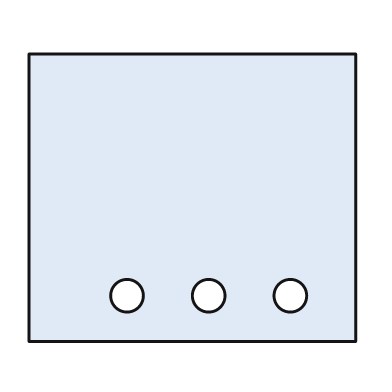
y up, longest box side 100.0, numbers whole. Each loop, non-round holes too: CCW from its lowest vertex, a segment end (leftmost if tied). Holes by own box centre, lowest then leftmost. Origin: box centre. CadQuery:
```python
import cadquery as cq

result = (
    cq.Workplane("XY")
    .moveTo(-50.0, -44.0)
    .lineTo(50.0, -44.0)
    .lineTo(50.0, 44.0)
    .lineTo(-50.0, 44.0)
    .close()
    .moveTo(-20.0, -30.0)
    .circle(5.0)
    .moveTo(5.0, -30.0)
    .circle(5.0)
    .moveTo(30.0, -30.0)
    .circle(5.0)
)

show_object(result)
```